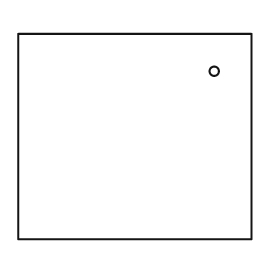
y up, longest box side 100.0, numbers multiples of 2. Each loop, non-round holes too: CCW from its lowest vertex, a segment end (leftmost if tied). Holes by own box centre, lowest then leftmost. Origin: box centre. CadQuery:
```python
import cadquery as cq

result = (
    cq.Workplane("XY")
    .moveTo(-50.0, -44.0)
    .lineTo(50.0, -44.0)
    .lineTo(50.0, 44.0)
    .lineTo(-50.0, 44.0)
    .close()
    .moveTo(34.0, 28.0)
    .circle(2.0)
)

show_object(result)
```